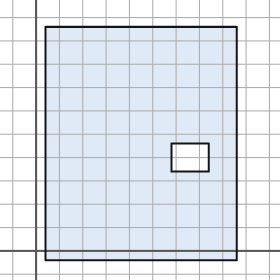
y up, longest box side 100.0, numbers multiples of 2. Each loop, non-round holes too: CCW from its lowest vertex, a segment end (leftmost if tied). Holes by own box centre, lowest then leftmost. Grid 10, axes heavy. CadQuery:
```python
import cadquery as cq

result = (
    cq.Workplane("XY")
    .moveTo(4.0, -4.0)
    .lineTo(86.0, -4.0)
    .lineTo(86.0, 96.0)
    .lineTo(4.0, 96.0)
    .close()
    .moveTo(58.0, 34.0)
    .lineTo(74.0, 34.0)
    .lineTo(74.0, 46.0)
    .lineTo(58.0, 46.0)
    .close()
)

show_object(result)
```